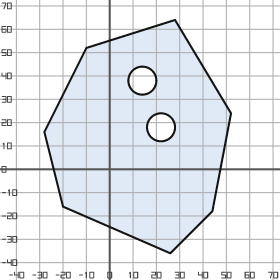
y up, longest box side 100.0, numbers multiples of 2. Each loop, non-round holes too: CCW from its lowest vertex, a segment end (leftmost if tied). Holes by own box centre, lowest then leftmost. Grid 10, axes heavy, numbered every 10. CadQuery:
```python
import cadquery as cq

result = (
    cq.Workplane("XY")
    .moveTo(26.0, -36.0)
    .lineTo(44.0, -18.0)
    .lineTo(52.0, 24.0)
    .lineTo(28.0, 64.0)
    .lineTo(-10.0, 52.0)
    .lineTo(-28.0, 16.0)
    .lineTo(-20.0, -16.0)
    .close()
    .moveTo(22.0, 18.0)
    .circle(6.0)
    .moveTo(14.0, 38.0)
    .circle(6.0)
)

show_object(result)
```